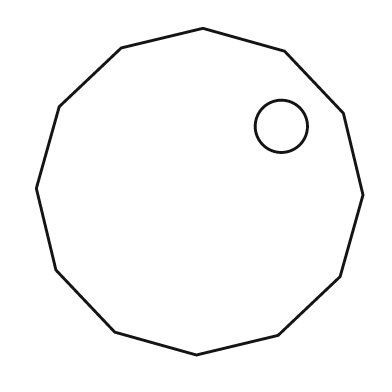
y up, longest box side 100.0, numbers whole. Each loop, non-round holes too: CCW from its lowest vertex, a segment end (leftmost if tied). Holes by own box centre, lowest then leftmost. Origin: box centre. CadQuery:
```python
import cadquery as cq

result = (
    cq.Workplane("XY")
    .moveTo(-1.0, -50.0)
    .lineTo(24.0, -44.0)
    .lineTo(43.0, -26.0)
    .lineTo(50.0, -1.0)
    .lineTo(44.0, 24.0)
    .lineTo(26.0, 43.0)
    .lineTo(1.0, 50.0)
    .lineTo(-24.0, 44.0)
    .lineTo(-43.0, 26.0)
    .lineTo(-50.0, 1.0)
    .lineTo(-44.0, -24.0)
    .lineTo(-26.0, -43.0)
    .close()
    .moveTo(25.0, 20.0)
    .circle(8.0)
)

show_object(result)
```